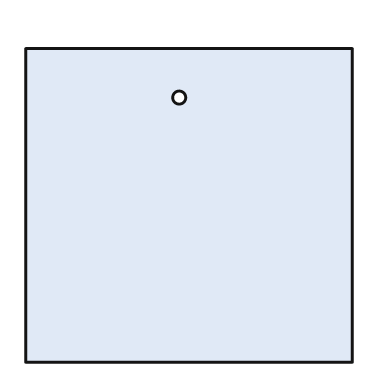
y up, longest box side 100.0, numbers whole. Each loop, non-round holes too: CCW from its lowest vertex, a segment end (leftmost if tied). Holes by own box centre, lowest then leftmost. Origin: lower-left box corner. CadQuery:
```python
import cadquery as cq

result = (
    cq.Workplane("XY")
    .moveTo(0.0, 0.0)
    .lineTo(100.0, 0.0)
    .lineTo(100.0, 96.0)
    .lineTo(0.0, 96.0)
    .close()
    .moveTo(47.0, 81.0)
    .circle(2.0)
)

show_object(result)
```